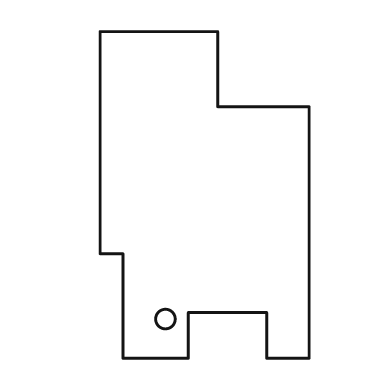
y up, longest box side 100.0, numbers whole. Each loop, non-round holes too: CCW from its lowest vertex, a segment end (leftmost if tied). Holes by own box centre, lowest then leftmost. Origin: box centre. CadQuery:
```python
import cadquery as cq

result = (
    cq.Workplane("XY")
    .moveTo(-25.0, -50.0)
    .lineTo(-5.0, -50.0)
    .lineTo(-5.0, -36.0)
    .lineTo(19.0, -36.0)
    .lineTo(19.0, -50.0)
    .lineTo(32.0, -50.0)
    .lineTo(32.0, 27.0)
    .lineTo(4.0, 27.0)
    .lineTo(4.0, 50.0)
    .lineTo(-32.0, 50.0)
    .lineTo(-32.0, -18.0)
    .lineTo(-25.0, -18.0)
    .close()
    .moveTo(-12.0, -38.0)
    .circle(3.0)
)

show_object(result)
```